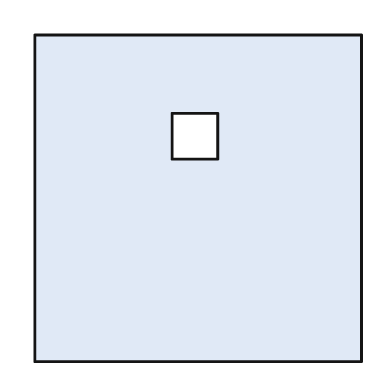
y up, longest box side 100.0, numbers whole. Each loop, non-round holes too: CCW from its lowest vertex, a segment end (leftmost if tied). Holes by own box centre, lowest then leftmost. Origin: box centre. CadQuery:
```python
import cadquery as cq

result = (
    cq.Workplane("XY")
    .moveTo(-50.0, -50.0)
    .lineTo(50.0, -50.0)
    .lineTo(50.0, 50.0)
    .lineTo(-50.0, 50.0)
    .close()
    .moveTo(-8.0, 12.0)
    .lineTo(6.0, 12.0)
    .lineTo(6.0, 26.0)
    .lineTo(-8.0, 26.0)
    .close()
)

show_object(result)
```